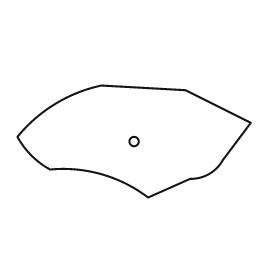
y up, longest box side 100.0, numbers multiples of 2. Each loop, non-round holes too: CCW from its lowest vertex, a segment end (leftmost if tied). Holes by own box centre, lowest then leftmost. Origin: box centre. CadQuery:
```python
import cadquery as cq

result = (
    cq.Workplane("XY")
    .moveTo(6.0, -24.0)
    .lineTo(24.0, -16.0)
    .threePointArc((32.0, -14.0), (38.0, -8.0))
    .lineTo(50.0, 8.0)
    .lineTo(22.0, 22.0)
    .lineTo(-14.0, 24.0)
    .threePointArc((-34.0, 16.0), (-50.0, 2.0))
    .threePointArc((-44.0, -6.0), (-36.0, -12.0))
    .threePointArc((-14.0, -14.0), (6.0, -24.0))
    .close()
    .moveTo(0.0, 0.0)
    .circle(2.0)
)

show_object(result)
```